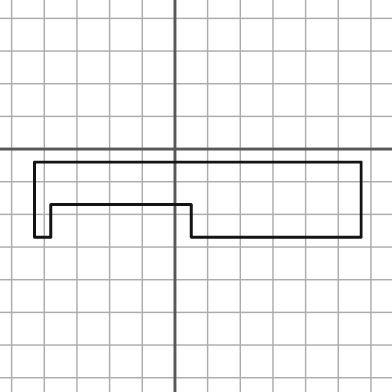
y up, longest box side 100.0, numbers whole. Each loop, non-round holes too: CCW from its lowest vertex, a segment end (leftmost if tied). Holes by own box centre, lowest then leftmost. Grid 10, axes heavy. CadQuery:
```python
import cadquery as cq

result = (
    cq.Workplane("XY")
    .moveTo(-43.0, -27.0)
    .lineTo(-38.0, -27.0)
    .lineTo(-38.0, -17.0)
    .lineTo(5.0, -17.0)
    .lineTo(5.0, -27.0)
    .lineTo(57.0, -27.0)
    .lineTo(57.0, -4.0)
    .lineTo(-43.0, -4.0)
    .close()
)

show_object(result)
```